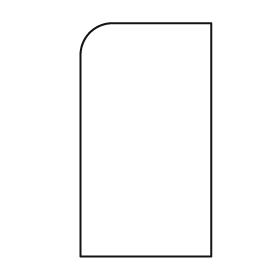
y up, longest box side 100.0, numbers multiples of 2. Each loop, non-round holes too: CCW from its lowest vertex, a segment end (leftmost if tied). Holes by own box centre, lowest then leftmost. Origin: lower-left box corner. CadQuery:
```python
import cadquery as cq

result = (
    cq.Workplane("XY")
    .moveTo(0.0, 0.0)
    .lineTo(56.0, 0.0)
    .lineTo(56.0, 100.0)
    .lineTo(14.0, 100.0)
    .threePointArc((4.0, 96.0), (0.0, 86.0))
    .close()
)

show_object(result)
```